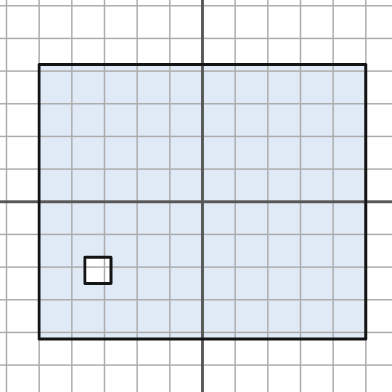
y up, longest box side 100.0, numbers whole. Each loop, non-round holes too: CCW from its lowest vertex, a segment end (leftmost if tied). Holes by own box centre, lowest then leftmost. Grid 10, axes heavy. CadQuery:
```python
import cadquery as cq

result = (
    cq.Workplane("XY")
    .moveTo(-50.0, -42.0)
    .lineTo(50.0, -42.0)
    .lineTo(50.0, 42.0)
    .lineTo(-50.0, 42.0)
    .close()
    .moveTo(-36.0, -25.0)
    .lineTo(-28.0, -25.0)
    .lineTo(-28.0, -17.0)
    .lineTo(-36.0, -17.0)
    .close()
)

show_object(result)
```